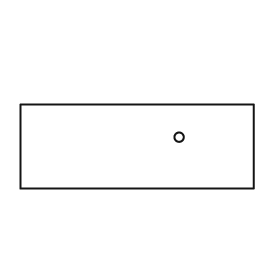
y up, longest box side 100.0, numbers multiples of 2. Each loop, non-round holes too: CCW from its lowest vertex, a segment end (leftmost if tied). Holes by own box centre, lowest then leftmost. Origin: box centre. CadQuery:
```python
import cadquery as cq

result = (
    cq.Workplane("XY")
    .moveTo(-50.0, -18.0)
    .lineTo(50.0, -18.0)
    .lineTo(50.0, 18.0)
    .lineTo(-50.0, 18.0)
    .close()
    .moveTo(18.0, 4.0)
    .circle(2.0)
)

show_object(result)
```